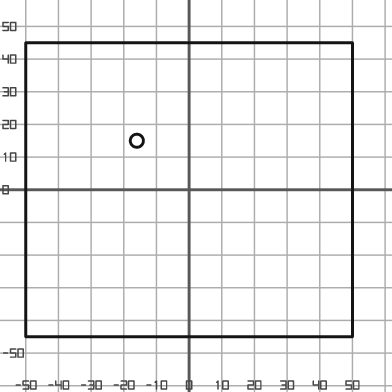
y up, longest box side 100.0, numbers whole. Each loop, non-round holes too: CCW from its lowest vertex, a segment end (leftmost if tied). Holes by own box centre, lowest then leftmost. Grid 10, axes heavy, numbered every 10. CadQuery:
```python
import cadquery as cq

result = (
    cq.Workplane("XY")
    .moveTo(-50.0, -45.0)
    .lineTo(50.0, -45.0)
    .lineTo(50.0, 45.0)
    .lineTo(-50.0, 45.0)
    .close()
    .moveTo(-16.0, 15.0)
    .circle(2.0)
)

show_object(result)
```